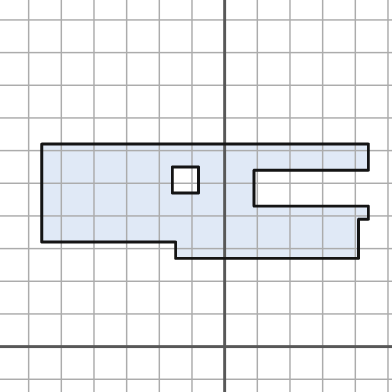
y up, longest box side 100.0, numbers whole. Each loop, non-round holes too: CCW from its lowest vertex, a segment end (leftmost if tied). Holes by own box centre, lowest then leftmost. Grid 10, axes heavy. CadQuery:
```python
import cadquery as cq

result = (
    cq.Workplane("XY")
    .moveTo(-15.0, 27.0)
    .lineTo(41.0, 27.0)
    .lineTo(41.0, 39.0)
    .lineTo(44.0, 39.0)
    .lineTo(44.0, 43.0)
    .lineTo(9.0, 43.0)
    .lineTo(9.0, 54.0)
    .lineTo(44.0, 54.0)
    .lineTo(44.0, 62.0)
    .lineTo(-56.0, 62.0)
    .lineTo(-56.0, 32.0)
    .lineTo(-15.0, 32.0)
    .close()
    .moveTo(-16.0, 47.0)
    .lineTo(-8.0, 47.0)
    .lineTo(-8.0, 55.0)
    .lineTo(-16.0, 55.0)
    .close()
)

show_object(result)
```